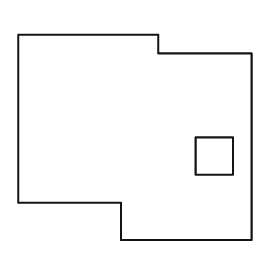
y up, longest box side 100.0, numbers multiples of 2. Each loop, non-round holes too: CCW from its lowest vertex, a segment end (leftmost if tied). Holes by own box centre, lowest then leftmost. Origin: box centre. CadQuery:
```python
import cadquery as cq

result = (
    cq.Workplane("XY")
    .moveTo(-6.0, -44.0)
    .lineTo(50.0, -44.0)
    .lineTo(50.0, 36.0)
    .lineTo(10.0, 36.0)
    .lineTo(10.0, 44.0)
    .lineTo(-50.0, 44.0)
    .lineTo(-50.0, -28.0)
    .lineTo(-6.0, -28.0)
    .close()
    .moveTo(26.0, -16.0)
    .lineTo(42.0, -16.0)
    .lineTo(42.0, 0.0)
    .lineTo(26.0, 0.0)
    .close()
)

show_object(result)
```